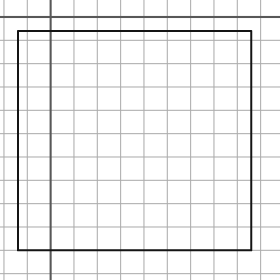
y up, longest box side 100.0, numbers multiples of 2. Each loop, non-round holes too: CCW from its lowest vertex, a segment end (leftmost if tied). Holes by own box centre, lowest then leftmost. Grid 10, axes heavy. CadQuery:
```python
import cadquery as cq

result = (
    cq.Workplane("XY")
    .moveTo(-14.0, -100.0)
    .lineTo(86.0, -100.0)
    .lineTo(86.0, -6.0)
    .lineTo(-14.0, -6.0)
    .close()
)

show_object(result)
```